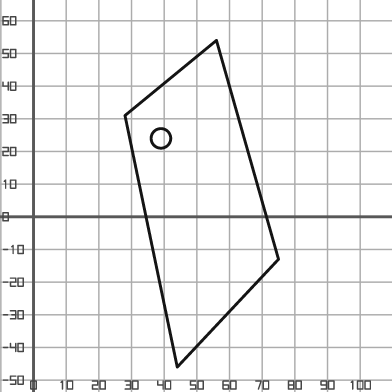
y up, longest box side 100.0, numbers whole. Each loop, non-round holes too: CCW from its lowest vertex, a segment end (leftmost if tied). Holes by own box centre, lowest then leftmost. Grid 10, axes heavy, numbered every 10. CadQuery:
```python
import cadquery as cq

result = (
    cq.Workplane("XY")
    .moveTo(44.0, -46.0)
    .lineTo(75.0, -13.0)
    .lineTo(56.0, 54.0)
    .lineTo(28.0, 31.0)
    .close()
    .moveTo(39.0, 24.0)
    .circle(3.0)
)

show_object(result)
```